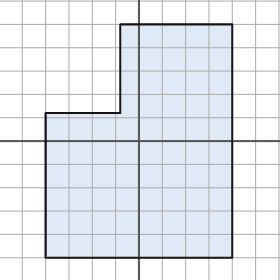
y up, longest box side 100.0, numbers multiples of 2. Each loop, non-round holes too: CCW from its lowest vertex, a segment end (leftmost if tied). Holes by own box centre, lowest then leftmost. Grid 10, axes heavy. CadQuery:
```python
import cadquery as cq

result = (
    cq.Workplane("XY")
    .moveTo(-40.0, -50.0)
    .lineTo(40.0, -50.0)
    .lineTo(40.0, 50.0)
    .lineTo(-8.0, 50.0)
    .lineTo(-8.0, 12.0)
    .lineTo(-40.0, 12.0)
    .close()
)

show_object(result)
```